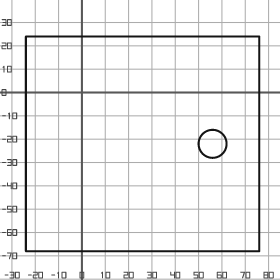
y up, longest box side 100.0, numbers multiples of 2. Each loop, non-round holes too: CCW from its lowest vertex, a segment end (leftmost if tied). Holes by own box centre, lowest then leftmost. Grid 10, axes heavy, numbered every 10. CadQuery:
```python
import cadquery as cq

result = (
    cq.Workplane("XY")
    .moveTo(-24.0, -68.0)
    .lineTo(76.0, -68.0)
    .lineTo(76.0, 24.0)
    .lineTo(-24.0, 24.0)
    .close()
    .moveTo(56.0, -22.0)
    .circle(6.0)
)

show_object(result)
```